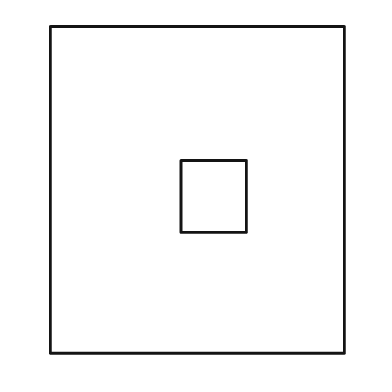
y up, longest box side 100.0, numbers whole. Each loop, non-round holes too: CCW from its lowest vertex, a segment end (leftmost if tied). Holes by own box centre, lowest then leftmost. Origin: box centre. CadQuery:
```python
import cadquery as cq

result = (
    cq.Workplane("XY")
    .moveTo(-45.0, -50.0)
    .lineTo(45.0, -50.0)
    .lineTo(45.0, 50.0)
    .lineTo(-45.0, 50.0)
    .close()
    .moveTo(-5.0, -13.0)
    .lineTo(15.0, -13.0)
    .lineTo(15.0, 9.0)
    .lineTo(-5.0, 9.0)
    .close()
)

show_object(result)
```